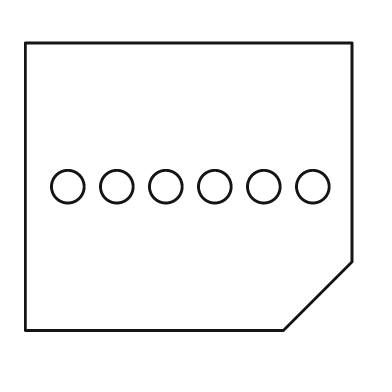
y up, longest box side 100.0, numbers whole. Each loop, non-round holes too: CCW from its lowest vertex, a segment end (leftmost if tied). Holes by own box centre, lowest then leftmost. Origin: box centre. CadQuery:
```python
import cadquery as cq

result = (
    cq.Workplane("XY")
    .moveTo(-50.0, -44.0)
    .lineTo(29.0, -44.0)
    .lineTo(50.0, -23.0)
    .lineTo(50.0, 44.0)
    .lineTo(-50.0, 44.0)
    .close()
    .moveTo(-37.0, 0.0)
    .circle(5.0)
    .moveTo(-22.0, 0.0)
    .circle(5.0)
    .moveTo(-7.0, 0.0)
    .circle(5.0)
    .moveTo(8.0, 0.0)
    .circle(5.0)
    .moveTo(23.0, 0.0)
    .circle(5.0)
    .moveTo(38.0, 0.0)
    .circle(5.0)
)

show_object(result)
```